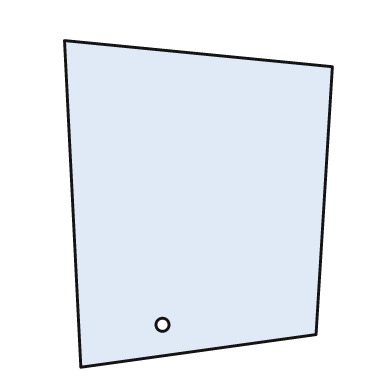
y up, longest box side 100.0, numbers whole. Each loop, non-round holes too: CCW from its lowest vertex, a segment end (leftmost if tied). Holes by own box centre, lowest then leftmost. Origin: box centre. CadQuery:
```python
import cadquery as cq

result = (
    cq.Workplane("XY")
    .moveTo(-36.0, -50.0)
    .lineTo(36.0, -40.0)
    .lineTo(41.0, 42.0)
    .lineTo(-41.0, 50.0)
    .close()
    .moveTo(-11.0, -37.0)
    .circle(2.0)
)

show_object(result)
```